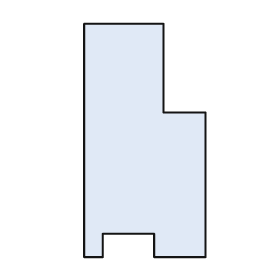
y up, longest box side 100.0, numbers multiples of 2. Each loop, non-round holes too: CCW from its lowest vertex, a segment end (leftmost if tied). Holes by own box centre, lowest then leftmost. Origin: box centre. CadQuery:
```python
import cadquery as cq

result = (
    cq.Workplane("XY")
    .moveTo(-26.0, -50.0)
    .lineTo(-18.0, -50.0)
    .lineTo(-18.0, -40.0)
    .lineTo(4.0, -40.0)
    .lineTo(4.0, -50.0)
    .lineTo(26.0, -50.0)
    .lineTo(26.0, 12.0)
    .lineTo(8.0, 12.0)
    .lineTo(8.0, 50.0)
    .lineTo(-26.0, 50.0)
    .close()
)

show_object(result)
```